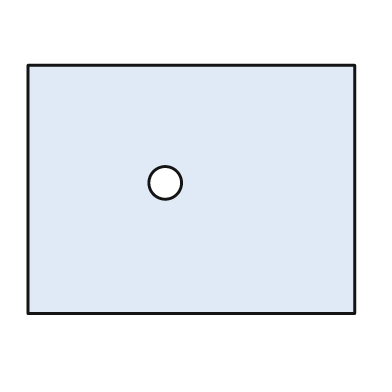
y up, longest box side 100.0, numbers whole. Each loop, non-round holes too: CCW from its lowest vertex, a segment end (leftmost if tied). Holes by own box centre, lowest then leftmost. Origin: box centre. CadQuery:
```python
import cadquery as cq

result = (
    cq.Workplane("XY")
    .moveTo(-50.0, -38.0)
    .lineTo(50.0, -38.0)
    .lineTo(50.0, 38.0)
    .lineTo(-50.0, 38.0)
    .close()
    .moveTo(-8.0, 2.0)
    .circle(5.0)
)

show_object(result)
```